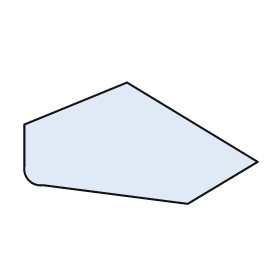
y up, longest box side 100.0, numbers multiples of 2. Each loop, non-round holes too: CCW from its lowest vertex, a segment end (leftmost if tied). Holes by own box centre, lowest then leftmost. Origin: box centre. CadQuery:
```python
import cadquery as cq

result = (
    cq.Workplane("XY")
    .moveTo(20.0, -26.0)
    .lineTo(50.0, -8.0)
    .lineTo(-6.0, 26.0)
    .lineTo(-50.0, 8.0)
    .lineTo(-50.0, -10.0)
    .threePointArc((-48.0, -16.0), (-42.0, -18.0))
    .close()
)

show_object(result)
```